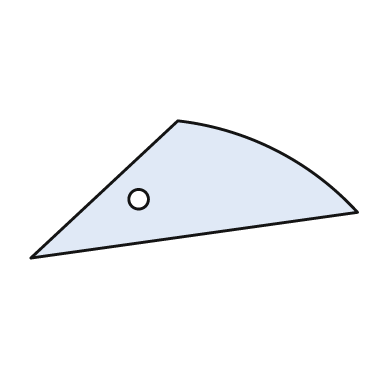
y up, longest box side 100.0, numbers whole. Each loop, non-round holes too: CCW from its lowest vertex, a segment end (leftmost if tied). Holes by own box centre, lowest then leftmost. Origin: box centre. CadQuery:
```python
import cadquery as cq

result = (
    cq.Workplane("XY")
    .moveTo(-50.0, -21.0)
    .lineTo(50.0, -7.0)
    .threePointArc((25.0, 12.0), (-5.0, 21.0))
    .close()
    .moveTo(-17.0, -3.0)
    .circle(3.0)
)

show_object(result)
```